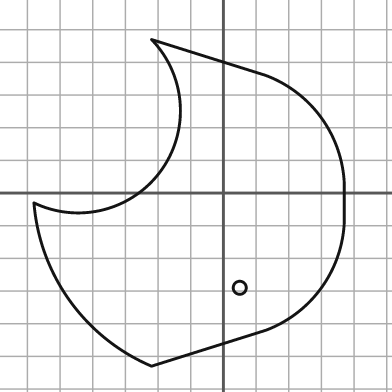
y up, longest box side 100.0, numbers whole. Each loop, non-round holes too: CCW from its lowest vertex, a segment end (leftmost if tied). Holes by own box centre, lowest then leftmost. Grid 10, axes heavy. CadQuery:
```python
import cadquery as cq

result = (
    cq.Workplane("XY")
    .moveTo(-22.0, -53.0)
    .lineTo(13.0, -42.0)
    .threePointArc((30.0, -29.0), (37.0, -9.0))
    .lineTo(37.0, 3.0)
    .threePointArc((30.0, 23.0), (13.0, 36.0))
    .lineTo(-22.0, 47.0)
    .threePointArc((-19.0, 7.0), (-58.0, -3.0))
    .threePointArc((-47.0, -33.0), (-22.0, -53.0))
    .close()
    .moveTo(5.0, -29.0)
    .circle(2.0)
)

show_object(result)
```